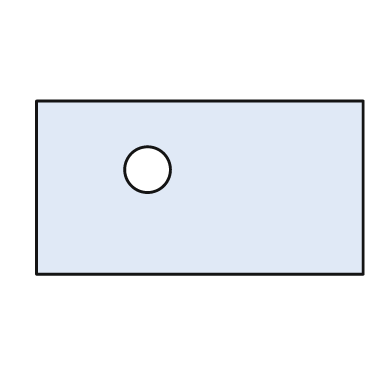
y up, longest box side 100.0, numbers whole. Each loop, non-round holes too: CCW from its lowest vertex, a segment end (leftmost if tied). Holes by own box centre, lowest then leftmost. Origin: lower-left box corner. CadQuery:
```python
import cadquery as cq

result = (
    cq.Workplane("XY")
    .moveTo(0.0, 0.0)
    .lineTo(100.0, 0.0)
    .lineTo(100.0, 53.0)
    .lineTo(0.0, 53.0)
    .close()
    .moveTo(34.0, 32.0)
    .circle(7.0)
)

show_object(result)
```